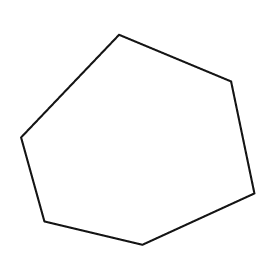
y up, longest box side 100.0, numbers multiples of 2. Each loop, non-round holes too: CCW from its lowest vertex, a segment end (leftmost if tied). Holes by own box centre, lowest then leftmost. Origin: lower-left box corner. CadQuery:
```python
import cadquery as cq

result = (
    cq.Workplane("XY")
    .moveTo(52.0, 0.0)
    .lineTo(100.0, 22.0)
    .lineTo(90.0, 70.0)
    .lineTo(42.0, 90.0)
    .lineTo(0.0, 46.0)
    .lineTo(10.0, 10.0)
    .close()
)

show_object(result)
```